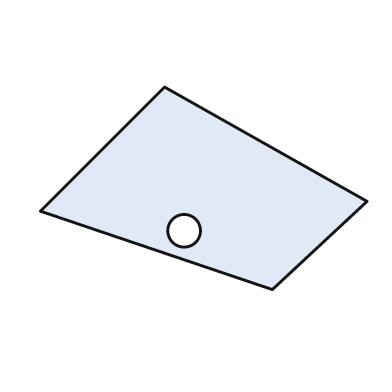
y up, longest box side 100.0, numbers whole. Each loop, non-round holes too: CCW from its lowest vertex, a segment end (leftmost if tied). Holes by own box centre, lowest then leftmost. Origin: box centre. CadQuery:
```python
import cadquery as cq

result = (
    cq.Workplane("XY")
    .moveTo(21.0, -31.0)
    .lineTo(50.0, -4.0)
    .lineTo(-12.0, 31.0)
    .lineTo(-50.0, -7.0)
    .close()
    .moveTo(-6.0, -13.0)
    .circle(5.0)
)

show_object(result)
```